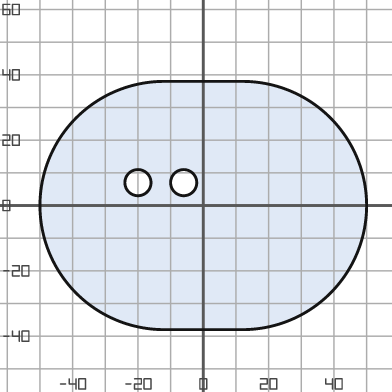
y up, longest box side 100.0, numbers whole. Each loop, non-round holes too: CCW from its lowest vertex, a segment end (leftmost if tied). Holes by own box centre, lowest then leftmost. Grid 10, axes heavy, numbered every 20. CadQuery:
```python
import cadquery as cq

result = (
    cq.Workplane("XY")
    .moveTo(-12.0, -38.0)
    .lineTo(12.0, -38.0)
    .threePointArc((50.0, 0.0), (12.0, 38.0))
    .lineTo(-12.0, 38.0)
    .threePointArc((-50.0, 0.0), (-12.0, -38.0))
    .close()
    .moveTo(-20.0, 7.0)
    .circle(4.0)
    .moveTo(-6.0, 7.0)
    .circle(4.0)
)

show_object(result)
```